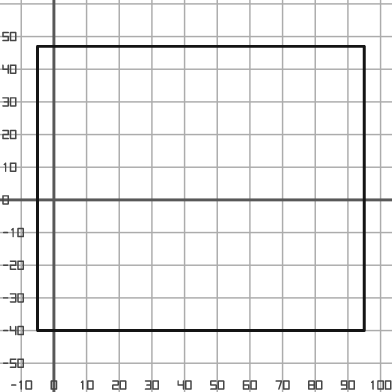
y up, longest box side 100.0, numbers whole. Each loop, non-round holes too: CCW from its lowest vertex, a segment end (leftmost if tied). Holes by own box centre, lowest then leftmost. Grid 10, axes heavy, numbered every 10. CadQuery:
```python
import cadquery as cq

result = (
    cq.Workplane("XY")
    .moveTo(-5.0, -40.0)
    .lineTo(95.0, -40.0)
    .lineTo(95.0, 47.0)
    .lineTo(-5.0, 47.0)
    .close()
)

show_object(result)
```